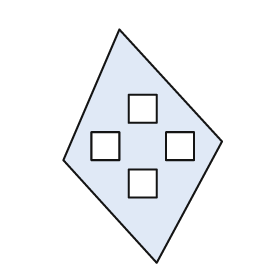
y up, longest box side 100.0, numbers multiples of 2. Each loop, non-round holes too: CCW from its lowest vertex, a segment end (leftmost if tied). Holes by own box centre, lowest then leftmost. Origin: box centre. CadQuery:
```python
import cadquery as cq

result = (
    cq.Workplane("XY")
    .moveTo(6.0, -50.0)
    .lineTo(34.0, 2.0)
    .lineTo(-10.0, 50.0)
    .lineTo(-34.0, -6.0)
    .close()
    .moveTo(-6.0, -22.0)
    .lineTo(6.0, -22.0)
    .lineTo(6.0, -10.0)
    .lineTo(-6.0, -10.0)
    .close()
    .moveTo(-22.0, -6.0)
    .lineTo(-10.0, -6.0)
    .lineTo(-10.0, 6.0)
    .lineTo(-22.0, 6.0)
    .close()
    .moveTo(10.0, -6.0)
    .lineTo(22.0, -6.0)
    .lineTo(22.0, 6.0)
    .lineTo(10.0, 6.0)
    .close()
    .moveTo(-6.0, 10.0)
    .lineTo(6.0, 10.0)
    .lineTo(6.0, 22.0)
    .lineTo(-6.0, 22.0)
    .close()
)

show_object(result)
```